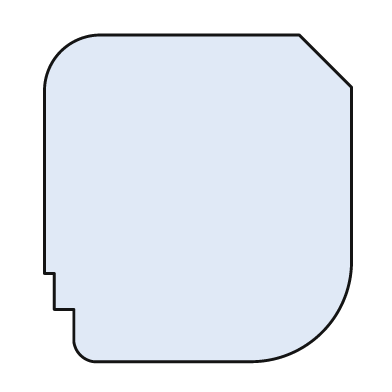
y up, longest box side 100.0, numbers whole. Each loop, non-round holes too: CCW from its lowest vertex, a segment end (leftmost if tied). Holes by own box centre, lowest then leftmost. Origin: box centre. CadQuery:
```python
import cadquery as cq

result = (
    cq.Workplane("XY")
    .moveTo(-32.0, -50.0)
    .lineTo(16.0, -50.0)
    .threePointArc((38.0, -41.0), (47.0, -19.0))
    .lineTo(47.0, 34.0)
    .lineTo(31.0, 50.0)
    .lineTo(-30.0, 50.0)
    .threePointArc((-42.0, 45.0), (-47.0, 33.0))
    .lineTo(-47.0, -23.0)
    .lineTo(-44.0, -23.0)
    .lineTo(-44.0, -34.0)
    .lineTo(-38.0, -34.0)
    .lineTo(-38.0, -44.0)
    .threePointArc((-36.0, -48.0), (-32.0, -50.0))
    .close()
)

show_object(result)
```